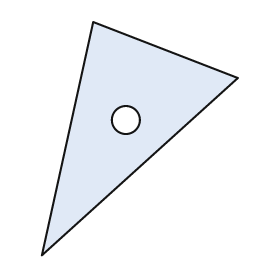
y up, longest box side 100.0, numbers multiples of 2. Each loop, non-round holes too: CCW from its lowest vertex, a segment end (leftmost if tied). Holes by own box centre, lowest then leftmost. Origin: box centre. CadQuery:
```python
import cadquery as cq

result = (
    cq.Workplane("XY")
    .moveTo(-42.0, -50.0)
    .lineTo(42.0, 26.0)
    .lineTo(-20.0, 50.0)
    .close()
    .moveTo(-6.0, 8.0)
    .circle(6.0)
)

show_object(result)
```